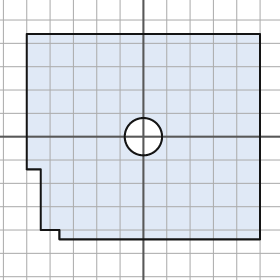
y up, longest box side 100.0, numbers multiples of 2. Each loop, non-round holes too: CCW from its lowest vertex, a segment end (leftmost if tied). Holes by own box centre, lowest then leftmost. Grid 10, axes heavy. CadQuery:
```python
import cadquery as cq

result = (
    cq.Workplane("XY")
    .moveTo(-36.0, -44.0)
    .lineTo(50.0, -44.0)
    .lineTo(50.0, 44.0)
    .lineTo(-50.0, 44.0)
    .lineTo(-50.0, -14.0)
    .lineTo(-44.0, -14.0)
    .lineTo(-44.0, -40.0)
    .lineTo(-36.0, -40.0)
    .close()
    .moveTo(0.0, 0.0)
    .circle(8.0)
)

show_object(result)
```